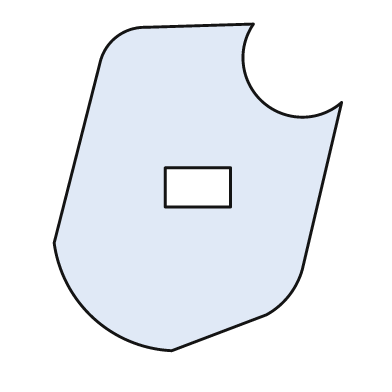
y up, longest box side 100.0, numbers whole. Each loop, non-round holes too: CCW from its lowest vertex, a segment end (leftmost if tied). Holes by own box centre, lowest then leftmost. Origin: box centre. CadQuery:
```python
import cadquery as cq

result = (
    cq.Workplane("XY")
    .moveTo(-8.0, -50.0)
    .lineTo(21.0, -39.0)
    .threePointArc((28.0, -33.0), (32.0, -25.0))
    .lineTo(44.0, 26.0)
    .threePointArc((20.0, 26.0), (17.0, 50.0))
    .lineTo(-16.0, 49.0)
    .threePointArc((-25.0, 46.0), (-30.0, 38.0))
    .lineTo(-44.0, -17.0)
    .threePointArc((-32.0, -40.0), (-8.0, -50.0))
    .close()
    .moveTo(-10.0, -6.0)
    .lineTo(10.0, -6.0)
    .lineTo(10.0, 6.0)
    .lineTo(-10.0, 6.0)
    .close()
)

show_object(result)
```